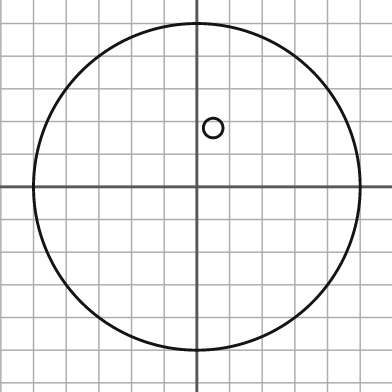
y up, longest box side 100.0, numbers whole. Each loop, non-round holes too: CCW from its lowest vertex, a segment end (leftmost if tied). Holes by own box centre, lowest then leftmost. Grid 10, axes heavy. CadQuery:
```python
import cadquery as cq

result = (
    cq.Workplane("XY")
    .moveTo(0.0, 0.0)
    .circle(50.0)
    .moveTo(5.0, 18.0)
    .circle(3.0)
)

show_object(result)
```